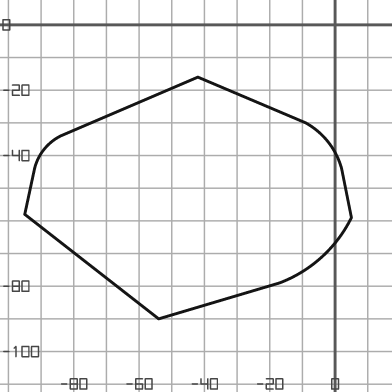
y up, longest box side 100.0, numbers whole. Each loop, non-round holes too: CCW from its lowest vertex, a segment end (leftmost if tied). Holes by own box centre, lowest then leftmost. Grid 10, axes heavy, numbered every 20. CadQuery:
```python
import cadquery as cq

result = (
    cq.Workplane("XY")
    .moveTo(-54.0, -90.0)
    .lineTo(-17.0, -79.0)
    .threePointArc((-4.0, -71.0), (5.0, -59.0))
    .lineTo(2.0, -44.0)
    .threePointArc((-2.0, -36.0), (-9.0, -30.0))
    .lineTo(-42.0, -16.0)
    .lineTo(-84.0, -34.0)
    .threePointArc((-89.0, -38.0), (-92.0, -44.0))
    .lineTo(-95.0, -58.0)
    .close()
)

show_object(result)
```